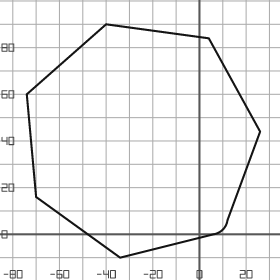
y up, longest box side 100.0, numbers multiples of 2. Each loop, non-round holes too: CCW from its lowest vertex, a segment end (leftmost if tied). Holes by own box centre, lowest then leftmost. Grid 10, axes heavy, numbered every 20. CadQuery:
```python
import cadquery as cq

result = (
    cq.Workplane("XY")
    .moveTo(-34.0, -10.0)
    .lineTo(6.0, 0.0)
    .threePointArc((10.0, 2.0), (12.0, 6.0))
    .lineTo(26.0, 44.0)
    .lineTo(4.0, 84.0)
    .lineTo(-40.0, 90.0)
    .lineTo(-74.0, 60.0)
    .lineTo(-70.0, 16.0)
    .close()
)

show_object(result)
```